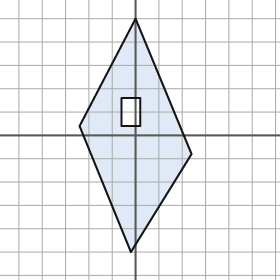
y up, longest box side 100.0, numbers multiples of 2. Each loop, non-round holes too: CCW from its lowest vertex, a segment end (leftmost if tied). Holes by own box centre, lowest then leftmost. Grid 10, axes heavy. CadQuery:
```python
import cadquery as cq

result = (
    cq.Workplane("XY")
    .moveTo(-2.0, -50.0)
    .lineTo(24.0, -8.0)
    .lineTo(0.0, 50.0)
    .lineTo(-24.0, 4.0)
    .close()
    .moveTo(-6.0, 4.0)
    .lineTo(2.0, 4.0)
    .lineTo(2.0, 16.0)
    .lineTo(-6.0, 16.0)
    .close()
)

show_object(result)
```